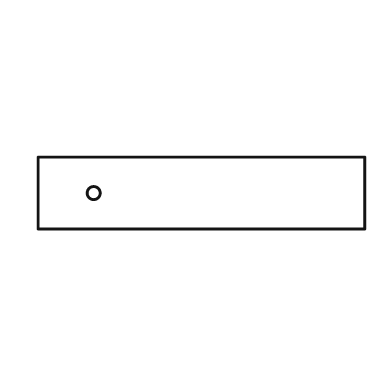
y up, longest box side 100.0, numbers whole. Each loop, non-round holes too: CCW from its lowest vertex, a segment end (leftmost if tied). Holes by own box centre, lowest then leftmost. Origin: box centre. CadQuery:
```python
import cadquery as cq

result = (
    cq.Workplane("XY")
    .moveTo(-50.0, -11.0)
    .lineTo(50.0, -11.0)
    .lineTo(50.0, 11.0)
    .lineTo(-50.0, 11.0)
    .close()
    .moveTo(-33.0, 0.0)
    .circle(2.0)
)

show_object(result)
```